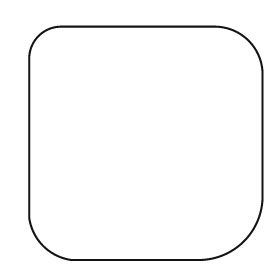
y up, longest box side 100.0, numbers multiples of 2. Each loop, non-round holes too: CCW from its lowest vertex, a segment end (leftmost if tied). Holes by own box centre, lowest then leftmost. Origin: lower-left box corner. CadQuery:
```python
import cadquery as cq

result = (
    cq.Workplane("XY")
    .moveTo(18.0, 0.0)
    .lineTo(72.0, 0.0)
    .threePointArc((92.0, 8.0), (100.0, 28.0))
    .lineTo(100.0, 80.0)
    .threePointArc((94.0, 94.0), (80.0, 100.0))
    .lineTo(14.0, 100.0)
    .threePointArc((4.0, 96.0), (0.0, 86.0))
    .lineTo(0.0, 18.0)
    .threePointArc((6.0, 6.0), (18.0, 0.0))
    .close()
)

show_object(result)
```